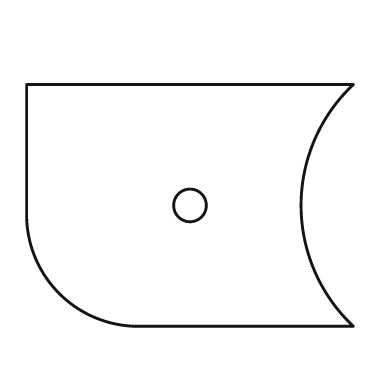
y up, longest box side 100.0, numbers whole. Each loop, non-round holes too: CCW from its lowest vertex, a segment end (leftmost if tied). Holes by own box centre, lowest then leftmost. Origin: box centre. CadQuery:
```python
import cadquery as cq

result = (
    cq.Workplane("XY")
    .moveTo(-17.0, -37.0)
    .lineTo(50.0, -37.0)
    .threePointArc((34.0, 0.0), (50.0, 37.0))
    .lineTo(-50.0, 37.0)
    .lineTo(-50.0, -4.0)
    .threePointArc((-40.0, -27.0), (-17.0, -37.0))
    .close()
    .moveTo(0.0, 0.0)
    .circle(5.0)
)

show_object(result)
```